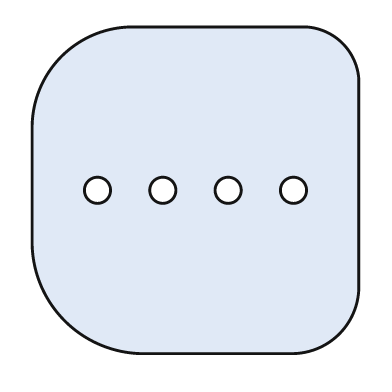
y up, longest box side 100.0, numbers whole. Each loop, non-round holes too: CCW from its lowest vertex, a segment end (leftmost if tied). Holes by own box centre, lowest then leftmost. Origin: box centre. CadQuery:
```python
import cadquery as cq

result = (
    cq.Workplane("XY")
    .moveTo(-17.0, -50.0)
    .lineTo(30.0, -50.0)
    .threePointArc((44.0, -44.0), (50.0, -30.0))
    .lineTo(50.0, 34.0)
    .threePointArc((45.0, 45.0), (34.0, 50.0))
    .lineTo(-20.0, 50.0)
    .threePointArc((-41.0, 41.0), (-50.0, 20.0))
    .lineTo(-50.0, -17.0)
    .threePointArc((-40.0, -40.0), (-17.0, -50.0))
    .close()
    .moveTo(-30.0, 0.0)
    .circle(4.0)
    .moveTo(-10.0, 0.0)
    .circle(4.0)
    .moveTo(10.0, 0.0)
    .circle(4.0)
    .moveTo(30.0, 0.0)
    .circle(4.0)
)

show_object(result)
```